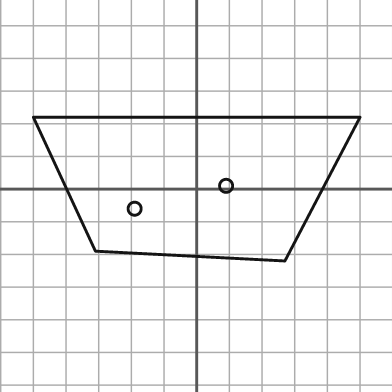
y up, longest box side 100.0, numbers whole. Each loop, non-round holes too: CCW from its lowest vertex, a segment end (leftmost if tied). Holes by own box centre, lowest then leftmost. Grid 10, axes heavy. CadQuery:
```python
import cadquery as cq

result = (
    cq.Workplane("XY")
    .moveTo(27.0, -22.0)
    .lineTo(50.0, 22.0)
    .lineTo(-50.0, 22.0)
    .lineTo(-31.0, -19.0)
    .close()
    .moveTo(-19.0, -6.0)
    .circle(2.0)
    .moveTo(9.0, 1.0)
    .circle(2.0)
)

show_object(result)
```